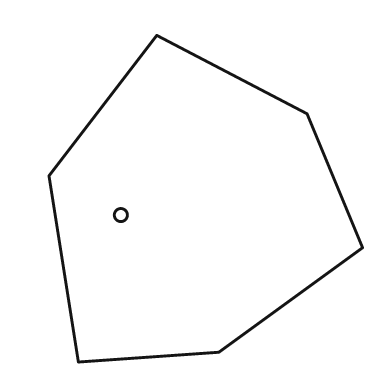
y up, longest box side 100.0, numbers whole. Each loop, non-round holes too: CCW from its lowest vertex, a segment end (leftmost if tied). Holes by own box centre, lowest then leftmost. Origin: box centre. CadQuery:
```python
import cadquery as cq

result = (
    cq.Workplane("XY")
    .moveTo(-39.0, -50.0)
    .lineTo(4.0, -47.0)
    .lineTo(48.0, -15.0)
    .lineTo(31.0, 26.0)
    .lineTo(-15.0, 50.0)
    .lineTo(-48.0, 7.0)
    .close()
    .moveTo(-26.0, -5.0)
    .circle(2.0)
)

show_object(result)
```